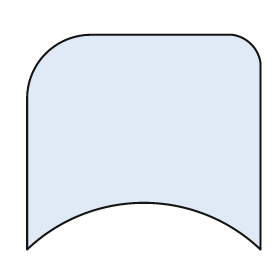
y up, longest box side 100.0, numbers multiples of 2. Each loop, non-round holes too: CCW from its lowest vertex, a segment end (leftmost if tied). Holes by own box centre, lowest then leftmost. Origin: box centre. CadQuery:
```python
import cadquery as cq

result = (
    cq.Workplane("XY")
    .moveTo(-50.0, -46.0)
    .threePointArc((0.0, -26.0), (50.0, -46.0))
    .lineTo(50.0, 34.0)
    .threePointArc((46.0, 42.0), (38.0, 46.0))
    .lineTo(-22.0, 46.0)
    .threePointArc((-42.0, 38.0), (-50.0, 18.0))
    .close()
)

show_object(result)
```